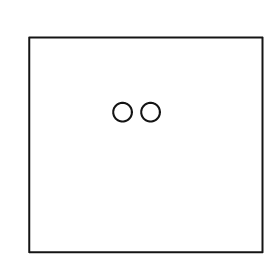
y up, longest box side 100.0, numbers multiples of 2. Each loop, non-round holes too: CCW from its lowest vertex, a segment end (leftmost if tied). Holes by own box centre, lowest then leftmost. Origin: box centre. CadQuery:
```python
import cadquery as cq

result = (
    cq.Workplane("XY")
    .moveTo(-50.0, -46.0)
    .lineTo(50.0, -46.0)
    .lineTo(50.0, 46.0)
    .lineTo(-50.0, 46.0)
    .close()
    .moveTo(-10.0, 14.0)
    .circle(4.0)
    .moveTo(2.0, 14.0)
    .circle(4.0)
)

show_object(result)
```